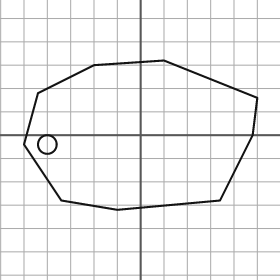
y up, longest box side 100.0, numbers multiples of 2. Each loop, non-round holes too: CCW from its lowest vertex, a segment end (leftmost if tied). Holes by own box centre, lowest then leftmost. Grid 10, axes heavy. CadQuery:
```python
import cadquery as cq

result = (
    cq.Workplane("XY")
    .moveTo(-10.0, -32.0)
    .lineTo(34.0, -28.0)
    .lineTo(48.0, 0.0)
    .lineTo(50.0, 16.0)
    .lineTo(10.0, 32.0)
    .lineTo(-20.0, 30.0)
    .lineTo(-44.0, 18.0)
    .lineTo(-50.0, -4.0)
    .lineTo(-34.0, -28.0)
    .close()
    .moveTo(-40.0, -4.0)
    .circle(4.0)
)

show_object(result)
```